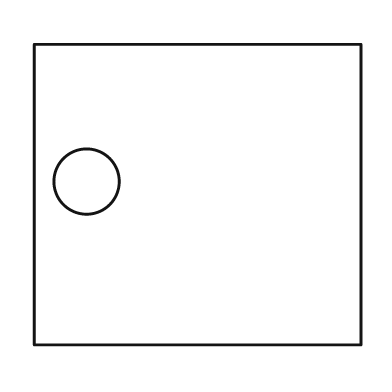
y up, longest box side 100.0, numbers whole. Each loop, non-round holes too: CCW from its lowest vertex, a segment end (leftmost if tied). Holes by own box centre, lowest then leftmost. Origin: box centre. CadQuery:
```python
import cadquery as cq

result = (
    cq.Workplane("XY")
    .moveTo(-50.0, -46.0)
    .lineTo(50.0, -46.0)
    .lineTo(50.0, 46.0)
    .lineTo(-50.0, 46.0)
    .close()
    .moveTo(-34.0, 4.0)
    .circle(10.0)
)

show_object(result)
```